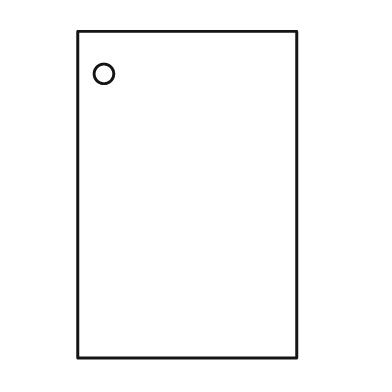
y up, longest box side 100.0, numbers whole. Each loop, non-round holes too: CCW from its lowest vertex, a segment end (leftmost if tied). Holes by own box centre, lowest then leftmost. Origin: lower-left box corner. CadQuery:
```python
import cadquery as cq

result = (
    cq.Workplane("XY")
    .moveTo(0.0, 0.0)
    .lineTo(67.0, 0.0)
    .lineTo(67.0, 100.0)
    .lineTo(0.0, 100.0)
    .close()
    .moveTo(8.0, 87.0)
    .circle(3.0)
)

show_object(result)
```